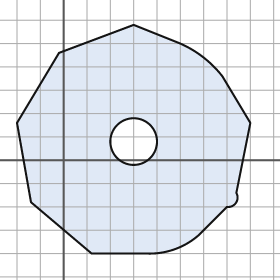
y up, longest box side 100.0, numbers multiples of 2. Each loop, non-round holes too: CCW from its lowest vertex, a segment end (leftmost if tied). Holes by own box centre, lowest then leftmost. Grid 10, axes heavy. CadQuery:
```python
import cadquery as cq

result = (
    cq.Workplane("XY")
    .moveTo(12.0, -40.0)
    .lineTo(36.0, -40.0)
    .threePointArc((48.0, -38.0), (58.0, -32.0))
    .lineTo(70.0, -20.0)
    .threePointArc((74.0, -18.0), (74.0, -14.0))
    .lineTo(80.0, 16.0)
    .lineTo(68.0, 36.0)
    .threePointArc((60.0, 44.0), (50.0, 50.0))
    .lineTo(30.0, 58.0)
    .lineTo(-2.0, 46.0)
    .lineTo(-20.0, 16.0)
    .lineTo(-14.0, -18.0)
    .close()
    .moveTo(30.0, 8.0)
    .circle(10.0)
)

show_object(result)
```